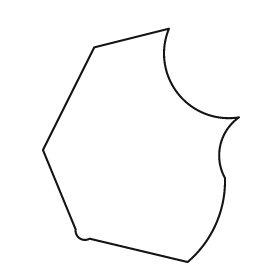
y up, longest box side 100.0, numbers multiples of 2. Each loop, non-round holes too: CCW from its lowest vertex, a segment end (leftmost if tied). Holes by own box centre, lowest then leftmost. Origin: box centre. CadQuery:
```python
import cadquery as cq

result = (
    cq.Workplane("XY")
    .moveTo(20.0, -50.0)
    .threePointArc((32.0, -34.0), (36.0, -14.0))
    .threePointArc((34.0, 0.0), (42.0, 12.0))
    .threePointArc((16.0, 22.0), (12.0, 50.0))
    .lineTo(-20.0, 42.0)
    .lineTo(-42.0, -2.0)
    .lineTo(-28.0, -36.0)
    .threePointArc((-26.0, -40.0), (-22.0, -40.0))
    .close()
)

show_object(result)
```